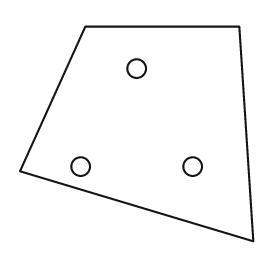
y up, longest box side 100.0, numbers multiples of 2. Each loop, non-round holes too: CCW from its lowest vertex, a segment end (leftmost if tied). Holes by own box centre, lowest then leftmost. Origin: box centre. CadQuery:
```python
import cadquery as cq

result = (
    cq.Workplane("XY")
    .moveTo(50.0, -46.0)
    .lineTo(44.0, 46.0)
    .lineTo(-22.0, 46.0)
    .lineTo(-50.0, -16.0)
    .close()
    .moveTo(-24.0, -14.0)
    .circle(4.0)
    .moveTo(24.0, -14.0)
    .circle(4.0)
    .moveTo(0.0, 28.0)
    .circle(4.0)
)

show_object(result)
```